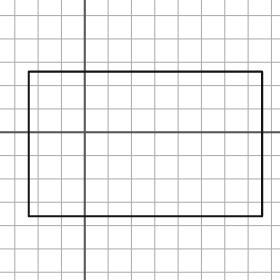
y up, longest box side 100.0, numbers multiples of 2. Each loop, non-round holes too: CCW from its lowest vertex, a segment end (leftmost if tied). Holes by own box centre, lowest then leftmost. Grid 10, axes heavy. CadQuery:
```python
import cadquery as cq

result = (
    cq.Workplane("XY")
    .moveTo(-24.0, -36.0)
    .lineTo(76.0, -36.0)
    .lineTo(76.0, 26.0)
    .lineTo(-24.0, 26.0)
    .close()
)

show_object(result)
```